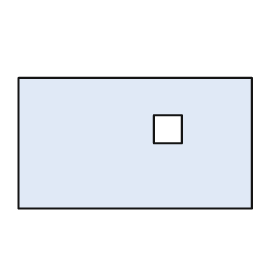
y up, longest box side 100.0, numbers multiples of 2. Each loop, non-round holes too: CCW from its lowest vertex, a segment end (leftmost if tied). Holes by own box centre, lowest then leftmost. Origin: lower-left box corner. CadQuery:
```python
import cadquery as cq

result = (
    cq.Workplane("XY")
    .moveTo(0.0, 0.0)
    .lineTo(100.0, 0.0)
    .lineTo(100.0, 56.0)
    .lineTo(0.0, 56.0)
    .close()
    .moveTo(58.0, 28.0)
    .lineTo(70.0, 28.0)
    .lineTo(70.0, 40.0)
    .lineTo(58.0, 40.0)
    .close()
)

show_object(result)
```